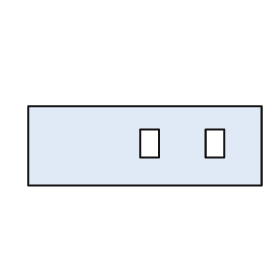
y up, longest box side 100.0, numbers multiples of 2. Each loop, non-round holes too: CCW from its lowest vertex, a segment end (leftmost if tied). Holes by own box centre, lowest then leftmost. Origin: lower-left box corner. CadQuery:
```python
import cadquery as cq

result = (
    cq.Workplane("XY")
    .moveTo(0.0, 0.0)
    .lineTo(100.0, 0.0)
    .lineTo(100.0, 34.0)
    .lineTo(0.0, 34.0)
    .close()
    .moveTo(48.0, 12.0)
    .lineTo(56.0, 12.0)
    .lineTo(56.0, 24.0)
    .lineTo(48.0, 24.0)
    .close()
    .moveTo(76.0, 12.0)
    .lineTo(84.0, 12.0)
    .lineTo(84.0, 24.0)
    .lineTo(76.0, 24.0)
    .close()
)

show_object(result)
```